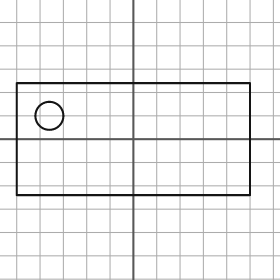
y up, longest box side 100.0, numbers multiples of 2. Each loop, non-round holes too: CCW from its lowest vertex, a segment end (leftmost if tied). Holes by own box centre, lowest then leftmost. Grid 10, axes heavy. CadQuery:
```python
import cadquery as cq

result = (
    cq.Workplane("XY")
    .moveTo(-50.0, -24.0)
    .lineTo(50.0, -24.0)
    .lineTo(50.0, 24.0)
    .lineTo(-50.0, 24.0)
    .close()
    .moveTo(-36.0, 10.0)
    .circle(6.0)
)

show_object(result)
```